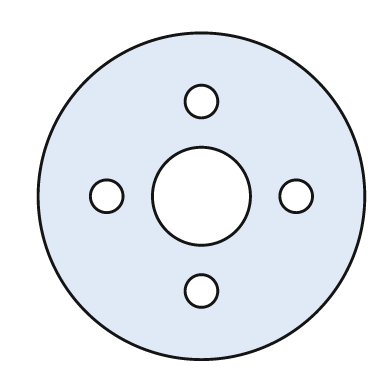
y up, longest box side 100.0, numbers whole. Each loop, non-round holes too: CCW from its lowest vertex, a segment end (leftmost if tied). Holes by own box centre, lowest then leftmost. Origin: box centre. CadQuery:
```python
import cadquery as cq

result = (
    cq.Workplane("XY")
    .moveTo(0.0, 0.0)
    .circle(50.0)
    .moveTo(0.0, -29.0)
    .circle(5.0)
    .moveTo(-29.0, 0.0)
    .circle(5.0)
    .moveTo(0.0, 0.0)
    .circle(15.0)
    .moveTo(29.0, 0.0)
    .circle(5.0)
    .moveTo(0.0, 29.0)
    .circle(5.0)
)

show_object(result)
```